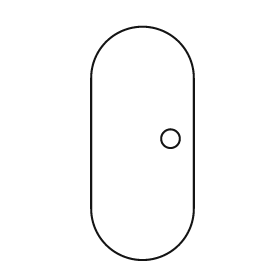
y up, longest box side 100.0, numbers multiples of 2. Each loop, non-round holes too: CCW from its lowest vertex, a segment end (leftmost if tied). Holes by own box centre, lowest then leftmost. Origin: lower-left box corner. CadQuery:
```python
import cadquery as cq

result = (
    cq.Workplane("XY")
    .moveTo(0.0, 22.0)
    .threePointArc((22.0, 0.0), (44.0, 22.0))
    .lineTo(44.0, 78.0)
    .threePointArc((22.0, 100.0), (0.0, 78.0))
    .close()
    .moveTo(34.0, 52.0)
    .circle(4.0)
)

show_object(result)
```